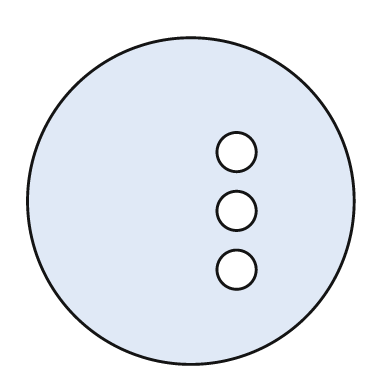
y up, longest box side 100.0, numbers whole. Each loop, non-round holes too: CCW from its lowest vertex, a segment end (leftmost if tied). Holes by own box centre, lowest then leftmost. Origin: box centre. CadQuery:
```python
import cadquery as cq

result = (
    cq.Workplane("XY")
    .moveTo(0.0, 0.0)
    .circle(50.0)
    .moveTo(14.0, -21.0)
    .circle(6.0)
    .moveTo(14.0, -3.0)
    .circle(6.0)
    .moveTo(14.0, 15.0)
    .circle(6.0)
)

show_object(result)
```